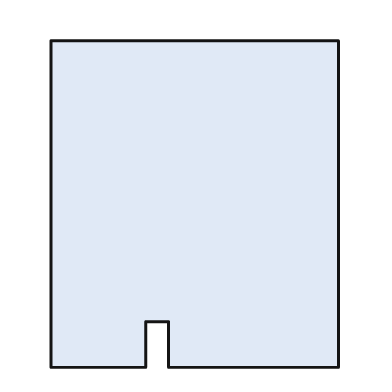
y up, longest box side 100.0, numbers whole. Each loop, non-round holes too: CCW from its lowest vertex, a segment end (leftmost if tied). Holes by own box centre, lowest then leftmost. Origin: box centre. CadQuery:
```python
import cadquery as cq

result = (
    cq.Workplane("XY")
    .moveTo(-44.0, -50.0)
    .lineTo(-15.0, -50.0)
    .lineTo(-15.0, -36.0)
    .lineTo(-8.0, -36.0)
    .lineTo(-8.0, -50.0)
    .lineTo(44.0, -50.0)
    .lineTo(44.0, 50.0)
    .lineTo(-44.0, 50.0)
    .close()
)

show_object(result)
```